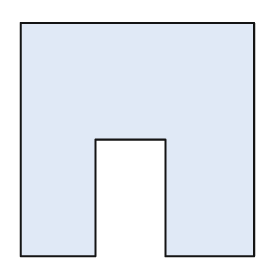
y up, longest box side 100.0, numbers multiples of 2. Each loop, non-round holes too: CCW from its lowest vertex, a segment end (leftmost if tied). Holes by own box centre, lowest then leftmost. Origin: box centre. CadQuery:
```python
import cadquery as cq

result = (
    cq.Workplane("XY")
    .moveTo(-50.0, -50.0)
    .lineTo(-18.0, -50.0)
    .lineTo(-18.0, 0.0)
    .lineTo(12.0, 0.0)
    .lineTo(12.0, -50.0)
    .lineTo(50.0, -50.0)
    .lineTo(50.0, 50.0)
    .lineTo(-50.0, 50.0)
    .close()
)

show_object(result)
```